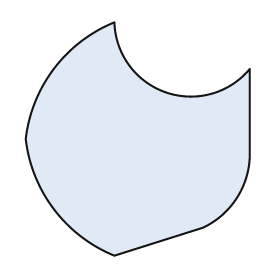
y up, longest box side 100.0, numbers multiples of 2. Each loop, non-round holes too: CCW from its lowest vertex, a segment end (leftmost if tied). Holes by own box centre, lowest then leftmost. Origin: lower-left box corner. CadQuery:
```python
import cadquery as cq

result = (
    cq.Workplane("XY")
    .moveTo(38.0, 0.0)
    .lineTo(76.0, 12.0)
    .threePointArc((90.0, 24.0), (96.0, 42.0))
    .lineTo(96.0, 80.0)
    .threePointArc((60.0, 70.0), (38.0, 100.0))
    .threePointArc((12.0, 80.0), (0.0, 50.0))
    .threePointArc((12.0, 20.0), (38.0, 0.0))
    .close()
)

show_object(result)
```